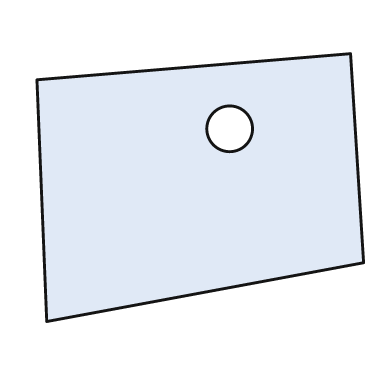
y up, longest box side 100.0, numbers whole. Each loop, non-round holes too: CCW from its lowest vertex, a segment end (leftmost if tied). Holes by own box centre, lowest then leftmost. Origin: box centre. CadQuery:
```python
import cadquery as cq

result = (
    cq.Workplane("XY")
    .moveTo(-47.0, -41.0)
    .lineTo(50.0, -23.0)
    .lineTo(46.0, 41.0)
    .lineTo(-50.0, 33.0)
    .close()
    .moveTo(9.0, 18.0)
    .circle(7.0)
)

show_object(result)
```